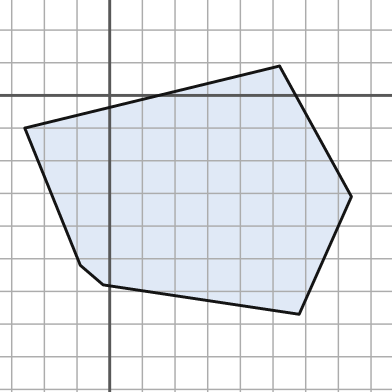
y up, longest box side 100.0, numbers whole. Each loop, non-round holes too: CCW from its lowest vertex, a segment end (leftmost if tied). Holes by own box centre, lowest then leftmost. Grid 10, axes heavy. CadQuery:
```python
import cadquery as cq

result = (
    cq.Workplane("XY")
    .moveTo(58.0, -67.0)
    .lineTo(74.0, -31.0)
    .lineTo(52.0, 9.0)
    .lineTo(-26.0, -10.0)
    .lineTo(-9.0, -52.0)
    .lineTo(-2.0, -58.0)
    .close()
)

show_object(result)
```